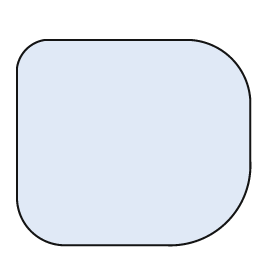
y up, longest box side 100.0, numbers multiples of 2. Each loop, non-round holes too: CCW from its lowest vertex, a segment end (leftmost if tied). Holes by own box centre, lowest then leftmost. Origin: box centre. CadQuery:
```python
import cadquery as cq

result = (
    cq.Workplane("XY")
    .moveTo(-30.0, -44.0)
    .lineTo(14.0, -44.0)
    .threePointArc((40.0, -34.0), (50.0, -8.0))
    .lineTo(50.0, 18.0)
    .threePointArc((42.0, 36.0), (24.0, 44.0))
    .lineTo(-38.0, 44.0)
    .threePointArc((-46.0, 40.0), (-50.0, 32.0))
    .lineTo(-50.0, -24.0)
    .threePointArc((-44.0, -38.0), (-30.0, -44.0))
    .close()
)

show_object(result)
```